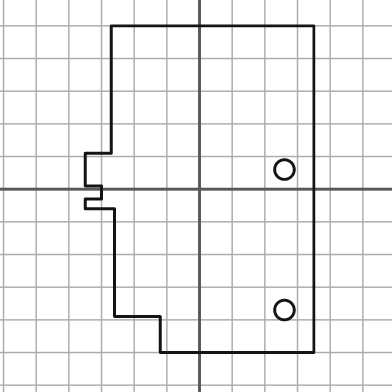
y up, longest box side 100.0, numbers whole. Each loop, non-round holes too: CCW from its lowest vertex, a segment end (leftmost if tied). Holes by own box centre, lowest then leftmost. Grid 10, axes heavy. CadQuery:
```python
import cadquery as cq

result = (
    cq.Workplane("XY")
    .moveTo(-12.0, -50.0)
    .lineTo(35.0, -50.0)
    .lineTo(35.0, 50.0)
    .lineTo(-27.0, 50.0)
    .lineTo(-27.0, 11.0)
    .lineTo(-35.0, 11.0)
    .lineTo(-35.0, 1.0)
    .lineTo(-30.0, 1.0)
    .lineTo(-30.0, -3.0)
    .lineTo(-35.0, -3.0)
    .lineTo(-35.0, -6.0)
    .lineTo(-26.0, -6.0)
    .lineTo(-26.0, -39.0)
    .lineTo(-12.0, -39.0)
    .close()
    .moveTo(26.0, -37.0)
    .circle(3.0)
    .moveTo(26.0, 6.0)
    .circle(3.0)
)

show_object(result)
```